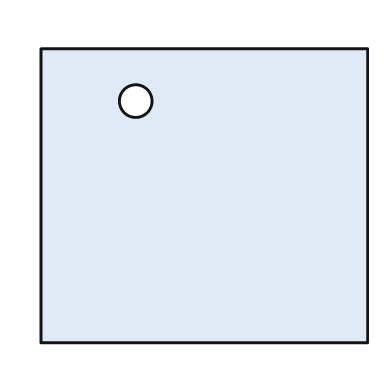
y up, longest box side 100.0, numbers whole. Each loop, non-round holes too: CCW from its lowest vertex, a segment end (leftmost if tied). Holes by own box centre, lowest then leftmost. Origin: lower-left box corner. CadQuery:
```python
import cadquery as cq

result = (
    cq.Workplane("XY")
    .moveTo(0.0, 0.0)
    .lineTo(100.0, 0.0)
    .lineTo(100.0, 90.0)
    .lineTo(0.0, 90.0)
    .close()
    .moveTo(29.0, 74.0)
    .circle(5.0)
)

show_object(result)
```